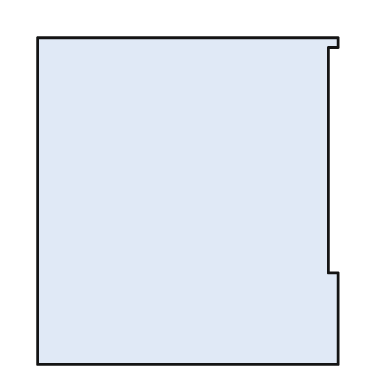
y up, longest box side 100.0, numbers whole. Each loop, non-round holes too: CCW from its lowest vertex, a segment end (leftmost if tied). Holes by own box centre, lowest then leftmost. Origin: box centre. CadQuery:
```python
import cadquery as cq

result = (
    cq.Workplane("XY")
    .moveTo(-46.0, -50.0)
    .lineTo(46.0, -50.0)
    .lineTo(46.0, -22.0)
    .lineTo(43.0, -22.0)
    .lineTo(43.0, 47.0)
    .lineTo(46.0, 47.0)
    .lineTo(46.0, 50.0)
    .lineTo(-46.0, 50.0)
    .close()
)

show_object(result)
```